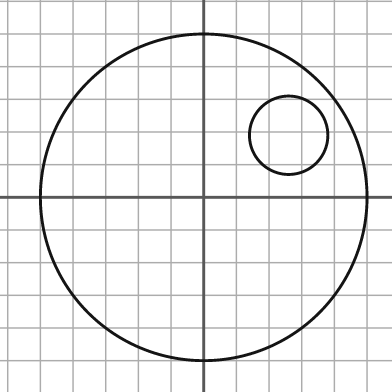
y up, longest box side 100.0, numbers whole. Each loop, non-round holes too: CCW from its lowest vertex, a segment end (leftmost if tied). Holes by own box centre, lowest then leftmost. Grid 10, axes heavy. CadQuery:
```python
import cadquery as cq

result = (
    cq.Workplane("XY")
    .moveTo(0.0, 0.0)
    .circle(50.0)
    .moveTo(26.0, 19.0)
    .circle(12.0)
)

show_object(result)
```